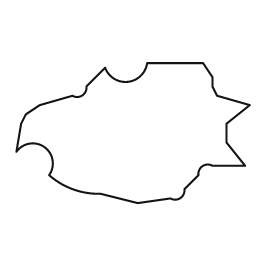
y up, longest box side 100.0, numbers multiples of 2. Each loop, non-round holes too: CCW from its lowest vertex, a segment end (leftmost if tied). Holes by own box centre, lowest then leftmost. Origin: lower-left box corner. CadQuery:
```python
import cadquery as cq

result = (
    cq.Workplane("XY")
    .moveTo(52.0, 0.0)
    .lineTo(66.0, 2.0)
    .threePointArc((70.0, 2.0), (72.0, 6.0))
    .lineTo(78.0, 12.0)
    .threePointArc((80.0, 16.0), (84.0, 16.0))
    .lineTo(98.0, 16.0)
    .lineTo(90.0, 26.0)
    .lineTo(90.0, 34.0)
    .lineTo(100.0, 42.0)
    .lineTo(86.0, 46.0)
    .lineTo(84.0, 50.0)
    .lineTo(84.0, 54.0)
    .lineTo(80.0, 60.0)
    .lineTo(56.0, 60.0)
    .threePointArc((48.0, 52.0), (38.0, 58.0))
    .lineTo(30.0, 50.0)
    .threePointArc((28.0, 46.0), (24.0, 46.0))
    .lineTo(10.0, 42.0)
    .lineTo(4.0, 38.0)
    .lineTo(2.0, 34.0)
    .lineTo(0.0, 22.0)
    .threePointArc((12.0, 24.0), (14.0, 12.0))
    .threePointArc((24.0, 6.0), (36.0, 4.0))
    .close()
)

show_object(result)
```